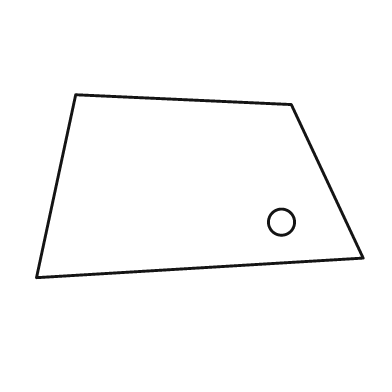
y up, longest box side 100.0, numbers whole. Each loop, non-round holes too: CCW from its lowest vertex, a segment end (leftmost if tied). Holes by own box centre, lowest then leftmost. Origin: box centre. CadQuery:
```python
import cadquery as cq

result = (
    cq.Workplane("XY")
    .moveTo(-50.0, -28.0)
    .lineTo(50.0, -22.0)
    .lineTo(28.0, 25.0)
    .lineTo(-38.0, 28.0)
    .close()
    .moveTo(25.0, -11.0)
    .circle(4.0)
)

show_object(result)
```